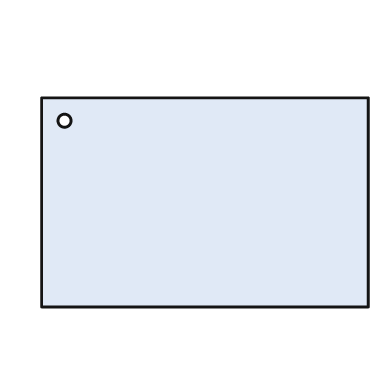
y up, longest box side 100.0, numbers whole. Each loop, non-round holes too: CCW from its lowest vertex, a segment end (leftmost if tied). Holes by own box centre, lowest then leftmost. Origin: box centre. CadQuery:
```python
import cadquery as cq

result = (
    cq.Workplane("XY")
    .moveTo(-50.0, -32.0)
    .lineTo(50.0, -32.0)
    .lineTo(50.0, 32.0)
    .lineTo(-50.0, 32.0)
    .close()
    .moveTo(-43.0, 25.0)
    .circle(2.0)
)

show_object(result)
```